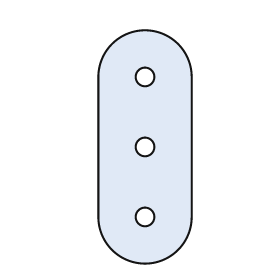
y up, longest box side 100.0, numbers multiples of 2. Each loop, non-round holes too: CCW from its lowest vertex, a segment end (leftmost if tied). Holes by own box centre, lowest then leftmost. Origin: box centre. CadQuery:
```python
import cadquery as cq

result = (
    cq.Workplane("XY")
    .moveTo(-20.0, -30.0)
    .threePointArc((0.0, -50.0), (20.0, -30.0))
    .lineTo(20.0, 30.0)
    .threePointArc((0.0, 50.0), (-20.0, 30.0))
    .close()
    .moveTo(0.0, -30.0)
    .circle(4.0)
    .moveTo(0.0, 0.0)
    .circle(4.0)
    .moveTo(0.0, 30.0)
    .circle(4.0)
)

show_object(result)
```